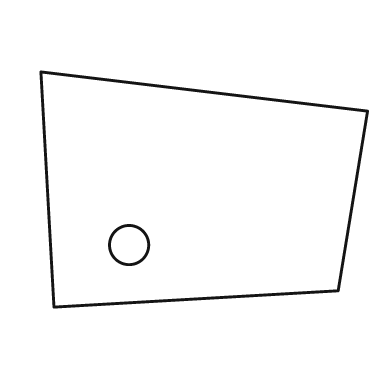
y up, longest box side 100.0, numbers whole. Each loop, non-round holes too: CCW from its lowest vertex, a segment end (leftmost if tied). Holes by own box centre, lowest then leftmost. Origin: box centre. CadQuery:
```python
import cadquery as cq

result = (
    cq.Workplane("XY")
    .moveTo(-46.0, -36.0)
    .lineTo(41.0, -31.0)
    .lineTo(50.0, 24.0)
    .lineTo(-50.0, 36.0)
    .close()
    .moveTo(-23.0, -17.0)
    .circle(6.0)
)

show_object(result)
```